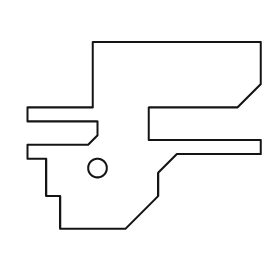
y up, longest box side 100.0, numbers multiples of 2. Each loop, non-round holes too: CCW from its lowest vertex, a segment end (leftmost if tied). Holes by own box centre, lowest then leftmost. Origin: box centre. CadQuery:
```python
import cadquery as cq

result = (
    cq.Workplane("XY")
    .moveTo(-36.0, -40.0)
    .lineTo(-8.0, -40.0)
    .lineTo(6.0, -26.0)
    .lineTo(6.0, -16.0)
    .lineTo(14.0, -8.0)
    .lineTo(50.0, -8.0)
    .lineTo(50.0, -2.0)
    .lineTo(2.0, -2.0)
    .lineTo(2.0, 12.0)
    .lineTo(40.0, 12.0)
    .lineTo(50.0, 22.0)
    .lineTo(50.0, 40.0)
    .lineTo(-22.0, 40.0)
    .lineTo(-22.0, 12.0)
    .lineTo(-50.0, 12.0)
    .lineTo(-50.0, 6.0)
    .lineTo(-20.0, 6.0)
    .lineTo(-20.0, 0.0)
    .lineTo(-24.0, -4.0)
    .lineTo(-50.0, -4.0)
    .lineTo(-50.0, -10.0)
    .lineTo(-42.0, -10.0)
    .lineTo(-42.0, -26.0)
    .lineTo(-36.0, -26.0)
    .close()
    .moveTo(-20.0, -14.0)
    .circle(4.0)
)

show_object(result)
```